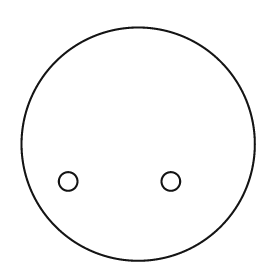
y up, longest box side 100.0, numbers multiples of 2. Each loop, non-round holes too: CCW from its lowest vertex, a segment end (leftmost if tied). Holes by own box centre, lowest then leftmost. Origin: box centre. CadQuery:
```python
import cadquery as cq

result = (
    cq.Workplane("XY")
    .moveTo(0.0, 0.0)
    .circle(50.0)
    .moveTo(-30.0, -16.0)
    .circle(4.0)
    .moveTo(14.0, -16.0)
    .circle(4.0)
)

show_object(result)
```